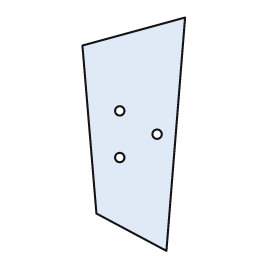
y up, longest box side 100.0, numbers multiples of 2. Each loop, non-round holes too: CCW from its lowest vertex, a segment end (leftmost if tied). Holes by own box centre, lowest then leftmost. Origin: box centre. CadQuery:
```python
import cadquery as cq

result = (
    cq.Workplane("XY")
    .moveTo(14.0, -50.0)
    .lineTo(22.0, 50.0)
    .lineTo(-22.0, 38.0)
    .lineTo(-16.0, -34.0)
    .close()
    .moveTo(-6.0, -10.0)
    .circle(2.0)
    .moveTo(10.0, 0.0)
    .circle(2.0)
    .moveTo(-6.0, 10.0)
    .circle(2.0)
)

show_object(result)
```